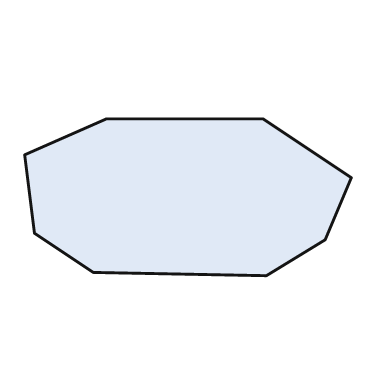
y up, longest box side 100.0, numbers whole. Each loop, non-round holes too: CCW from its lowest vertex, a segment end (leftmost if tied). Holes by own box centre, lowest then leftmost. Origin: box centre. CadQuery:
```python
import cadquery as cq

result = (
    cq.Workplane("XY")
    .moveTo(24.0, -24.0)
    .lineTo(42.0, -13.0)
    .lineTo(50.0, 6.0)
    .lineTo(23.0, 24.0)
    .lineTo(-25.0, 24.0)
    .lineTo(-50.0, 13.0)
    .lineTo(-47.0, -11.0)
    .lineTo(-29.0, -23.0)
    .close()
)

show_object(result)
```